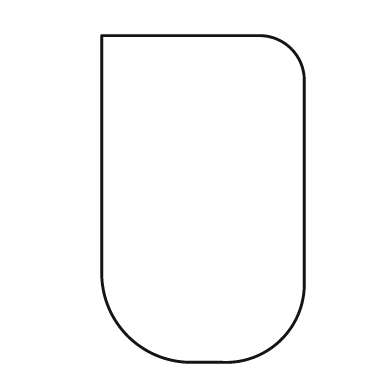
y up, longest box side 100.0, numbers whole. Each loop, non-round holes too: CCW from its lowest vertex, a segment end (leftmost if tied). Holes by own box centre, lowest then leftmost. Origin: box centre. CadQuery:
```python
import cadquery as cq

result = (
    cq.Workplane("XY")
    .moveTo(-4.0, -50.0)
    .lineTo(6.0, -50.0)
    .threePointArc((24.0, -43.0), (31.0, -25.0))
    .lineTo(31.0, 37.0)
    .threePointArc((27.0, 46.0), (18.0, 50.0))
    .lineTo(-31.0, 50.0)
    .lineTo(-31.0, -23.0)
    .threePointArc((-23.0, -42.0), (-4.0, -50.0))
    .close()
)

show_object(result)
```